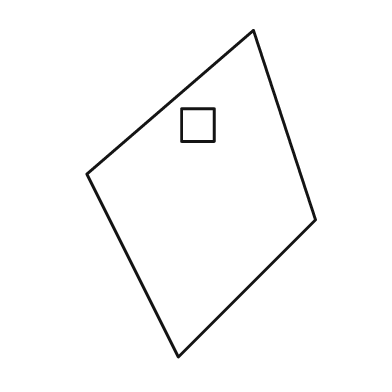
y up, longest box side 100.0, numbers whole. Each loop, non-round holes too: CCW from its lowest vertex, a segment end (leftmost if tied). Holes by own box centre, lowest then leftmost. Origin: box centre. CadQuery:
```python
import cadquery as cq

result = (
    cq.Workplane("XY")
    .moveTo(-7.0, -50.0)
    .lineTo(35.0, -8.0)
    .lineTo(16.0, 50.0)
    .lineTo(-35.0, 6.0)
    .close()
    .moveTo(-6.0, 16.0)
    .lineTo(4.0, 16.0)
    .lineTo(4.0, 26.0)
    .lineTo(-6.0, 26.0)
    .close()
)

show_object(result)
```